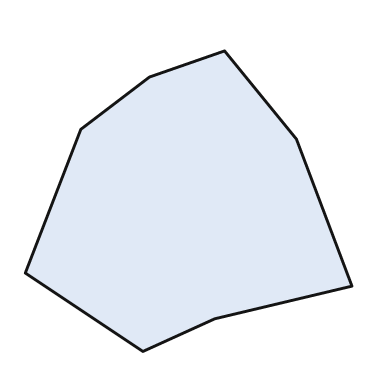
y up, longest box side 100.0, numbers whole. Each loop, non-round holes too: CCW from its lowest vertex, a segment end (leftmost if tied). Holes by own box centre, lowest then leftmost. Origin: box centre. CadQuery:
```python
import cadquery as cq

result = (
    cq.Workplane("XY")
    .moveTo(-14.0, -46.0)
    .lineTo(8.0, -36.0)
    .lineTo(50.0, -26.0)
    .lineTo(33.0, 19.0)
    .lineTo(11.0, 46.0)
    .lineTo(-12.0, 38.0)
    .lineTo(-33.0, 22.0)
    .lineTo(-50.0, -22.0)
    .close()
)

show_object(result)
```